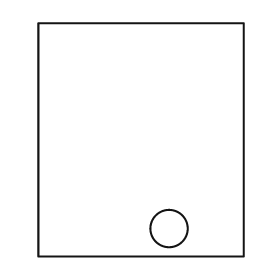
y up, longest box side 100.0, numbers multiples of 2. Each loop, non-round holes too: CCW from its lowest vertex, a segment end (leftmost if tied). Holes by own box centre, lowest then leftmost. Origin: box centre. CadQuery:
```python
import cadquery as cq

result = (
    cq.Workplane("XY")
    .moveTo(-44.0, -50.0)
    .lineTo(44.0, -50.0)
    .lineTo(44.0, 50.0)
    .lineTo(-44.0, 50.0)
    .close()
    .moveTo(12.0, -38.0)
    .circle(8.0)
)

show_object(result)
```